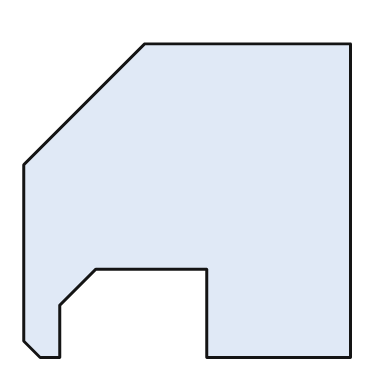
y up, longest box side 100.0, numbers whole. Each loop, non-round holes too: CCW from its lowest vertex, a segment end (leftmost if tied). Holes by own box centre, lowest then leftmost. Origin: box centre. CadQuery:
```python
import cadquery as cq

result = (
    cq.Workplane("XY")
    .moveTo(-45.0, -48.0)
    .lineTo(-39.0, -48.0)
    .lineTo(-39.0, -32.0)
    .lineTo(-28.0, -21.0)
    .lineTo(6.0, -21.0)
    .lineTo(6.0, -48.0)
    .lineTo(50.0, -48.0)
    .lineTo(50.0, 48.0)
    .lineTo(-13.0, 48.0)
    .lineTo(-50.0, 11.0)
    .lineTo(-50.0, -43.0)
    .close()
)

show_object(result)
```